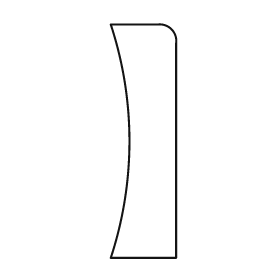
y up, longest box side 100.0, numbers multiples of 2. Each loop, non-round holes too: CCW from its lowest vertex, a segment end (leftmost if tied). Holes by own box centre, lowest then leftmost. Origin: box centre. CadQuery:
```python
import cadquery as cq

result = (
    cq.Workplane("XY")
    .moveTo(-14.0, -50.0)
    .lineTo(14.0, -50.0)
    .lineTo(14.0, 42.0)
    .threePointArc((12.0, 48.0), (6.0, 50.0))
    .lineTo(-14.0, 50.0)
    .threePointArc((-6.0, 0.0), (-14.0, -50.0))
    .close()
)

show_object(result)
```